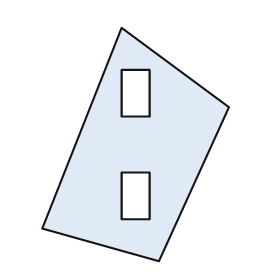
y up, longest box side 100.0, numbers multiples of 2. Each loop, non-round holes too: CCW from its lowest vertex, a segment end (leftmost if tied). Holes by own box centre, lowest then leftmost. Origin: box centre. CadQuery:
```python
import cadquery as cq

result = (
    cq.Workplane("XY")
    .moveTo(10.0, -50.0)
    .lineTo(40.0, 16.0)
    .lineTo(-6.0, 50.0)
    .lineTo(-40.0, -36.0)
    .close()
    .moveTo(-6.0, -32.0)
    .lineTo(6.0, -32.0)
    .lineTo(6.0, -12.0)
    .lineTo(-6.0, -12.0)
    .close()
    .moveTo(-6.0, 12.0)
    .lineTo(6.0, 12.0)
    .lineTo(6.0, 32.0)
    .lineTo(-6.0, 32.0)
    .close()
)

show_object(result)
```